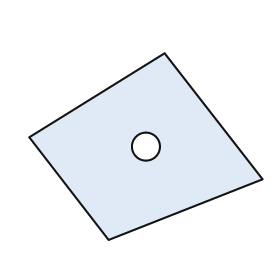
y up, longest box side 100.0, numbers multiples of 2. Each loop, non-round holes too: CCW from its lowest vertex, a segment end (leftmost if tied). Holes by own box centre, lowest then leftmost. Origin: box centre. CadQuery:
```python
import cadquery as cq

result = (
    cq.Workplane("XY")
    .moveTo(-16.0, -40.0)
    .lineTo(50.0, -14.0)
    .lineTo(8.0, 40.0)
    .lineTo(-50.0, 4.0)
    .close()
    .moveTo(0.0, 0.0)
    .circle(6.0)
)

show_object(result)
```